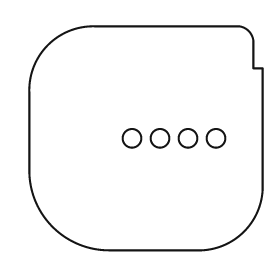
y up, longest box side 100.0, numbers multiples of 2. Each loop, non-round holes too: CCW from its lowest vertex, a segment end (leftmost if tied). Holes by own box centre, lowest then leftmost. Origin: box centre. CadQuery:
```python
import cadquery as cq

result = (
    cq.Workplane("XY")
    .moveTo(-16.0, -48.0)
    .lineTo(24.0, -48.0)
    .threePointArc((42.0, -40.0), (50.0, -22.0))
    .lineTo(50.0, 30.0)
    .lineTo(46.0, 30.0)
    .lineTo(46.0, 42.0)
    .threePointArc((44.0, 46.0), (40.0, 48.0))
    .lineTo(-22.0, 48.0)
    .threePointArc((-42.0, 40.0), (-50.0, 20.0))
    .lineTo(-50.0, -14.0)
    .threePointArc((-40.0, -38.0), (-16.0, -48.0))
    .close()
    .moveTo(-6.0, 0.0)
    .circle(4.0)
    .moveTo(6.0, 0.0)
    .circle(4.0)
    .moveTo(18.0, 0.0)
    .circle(4.0)
    .moveTo(30.0, 0.0)
    .circle(4.0)
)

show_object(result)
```